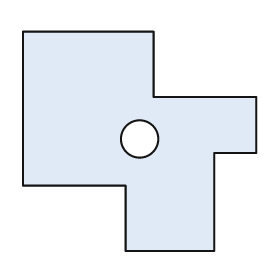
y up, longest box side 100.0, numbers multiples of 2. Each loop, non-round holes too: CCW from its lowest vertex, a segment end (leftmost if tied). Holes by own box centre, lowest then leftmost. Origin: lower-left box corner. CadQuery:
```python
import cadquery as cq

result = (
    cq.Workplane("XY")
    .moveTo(44.0, 0.0)
    .lineTo(82.0, 0.0)
    .lineTo(82.0, 42.0)
    .lineTo(100.0, 42.0)
    .lineTo(100.0, 66.0)
    .lineTo(56.0, 66.0)
    .lineTo(56.0, 94.0)
    .lineTo(0.0, 94.0)
    .lineTo(0.0, 28.0)
    .lineTo(44.0, 28.0)
    .close()
    .moveTo(50.0, 48.0)
    .circle(8.0)
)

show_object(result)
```